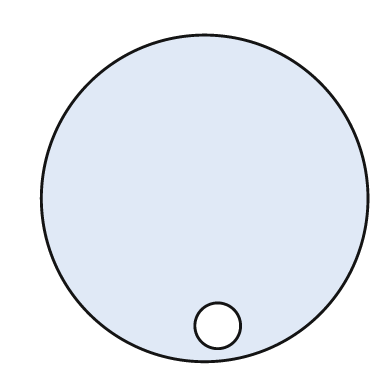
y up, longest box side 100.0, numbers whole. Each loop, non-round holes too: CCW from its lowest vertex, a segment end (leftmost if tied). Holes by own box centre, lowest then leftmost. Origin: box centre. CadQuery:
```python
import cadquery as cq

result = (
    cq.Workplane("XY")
    .moveTo(0.0, 0.0)
    .circle(50.0)
    .moveTo(4.0, -39.0)
    .circle(7.0)
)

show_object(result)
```